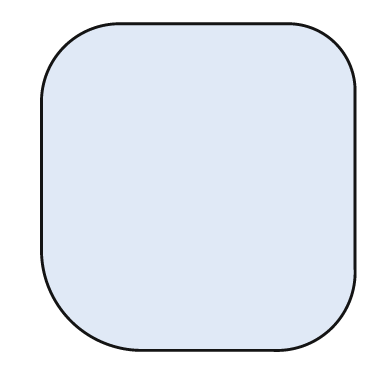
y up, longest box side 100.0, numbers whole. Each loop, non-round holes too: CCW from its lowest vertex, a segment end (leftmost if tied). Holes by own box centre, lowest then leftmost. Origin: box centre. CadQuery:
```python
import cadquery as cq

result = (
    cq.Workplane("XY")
    .moveTo(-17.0, -50.0)
    .lineTo(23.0, -50.0)
    .threePointArc((41.0, -43.0), (48.0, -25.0))
    .lineTo(48.0, 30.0)
    .threePointArc((42.0, 44.0), (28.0, 50.0))
    .lineTo(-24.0, 50.0)
    .threePointArc((-41.0, 43.0), (-48.0, 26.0))
    .lineTo(-48.0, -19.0)
    .threePointArc((-39.0, -41.0), (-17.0, -50.0))
    .close()
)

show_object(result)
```